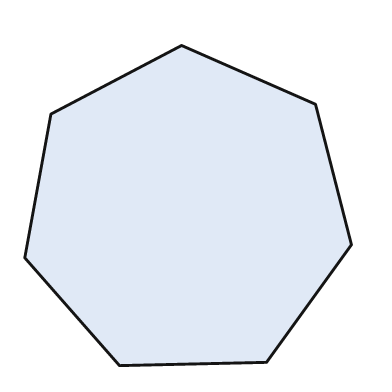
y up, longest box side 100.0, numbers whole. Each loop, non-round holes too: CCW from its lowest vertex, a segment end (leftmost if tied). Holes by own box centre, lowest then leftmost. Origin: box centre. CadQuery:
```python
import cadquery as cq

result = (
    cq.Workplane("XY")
    .moveTo(-21.0, -49.0)
    .lineTo(24.0, -48.0)
    .lineTo(50.0, -12.0)
    .lineTo(39.0, 31.0)
    .lineTo(-2.0, 49.0)
    .lineTo(-42.0, 28.0)
    .lineTo(-50.0, -16.0)
    .close()
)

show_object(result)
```